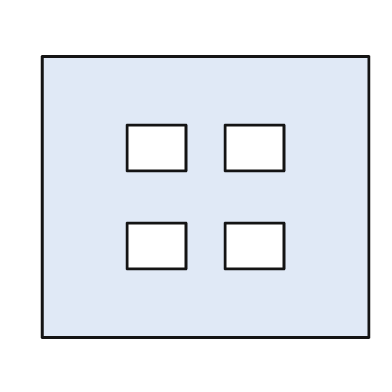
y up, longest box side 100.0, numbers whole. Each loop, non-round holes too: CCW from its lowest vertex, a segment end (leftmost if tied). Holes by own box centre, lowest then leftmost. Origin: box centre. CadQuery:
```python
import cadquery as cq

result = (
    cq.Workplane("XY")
    .moveTo(-50.0, -43.0)
    .lineTo(50.0, -43.0)
    .lineTo(50.0, 43.0)
    .lineTo(-50.0, 43.0)
    .close()
    .moveTo(-24.0, -22.0)
    .lineTo(-6.0, -22.0)
    .lineTo(-6.0, -8.0)
    .lineTo(-24.0, -8.0)
    .close()
    .moveTo(6.0, -22.0)
    .lineTo(24.0, -22.0)
    .lineTo(24.0, -8.0)
    .lineTo(6.0, -8.0)
    .close()
    .moveTo(-24.0, 8.0)
    .lineTo(-6.0, 8.0)
    .lineTo(-6.0, 22.0)
    .lineTo(-24.0, 22.0)
    .close()
    .moveTo(6.0, 8.0)
    .lineTo(24.0, 8.0)
    .lineTo(24.0, 22.0)
    .lineTo(6.0, 22.0)
    .close()
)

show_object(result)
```